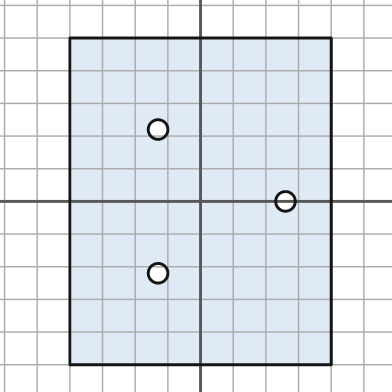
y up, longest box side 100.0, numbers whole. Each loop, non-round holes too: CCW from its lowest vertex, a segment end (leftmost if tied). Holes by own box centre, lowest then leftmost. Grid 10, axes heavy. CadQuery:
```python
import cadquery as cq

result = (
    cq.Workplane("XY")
    .moveTo(-40.0, -50.0)
    .lineTo(40.0, -50.0)
    .lineTo(40.0, 50.0)
    .lineTo(-40.0, 50.0)
    .close()
    .moveTo(-13.0, -22.0)
    .circle(3.0)
    .moveTo(26.0, 0.0)
    .circle(3.0)
    .moveTo(-13.0, 22.0)
    .circle(3.0)
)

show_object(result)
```